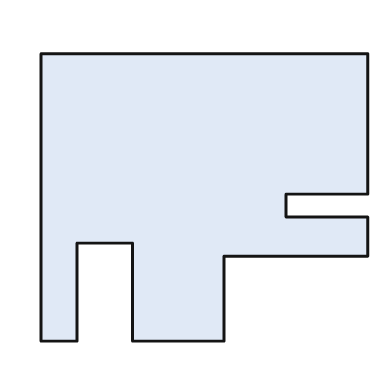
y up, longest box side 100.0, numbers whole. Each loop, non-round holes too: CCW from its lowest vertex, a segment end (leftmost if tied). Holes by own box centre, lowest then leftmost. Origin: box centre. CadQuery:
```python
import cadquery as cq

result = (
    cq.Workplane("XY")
    .moveTo(-50.0, -44.0)
    .lineTo(-39.0, -44.0)
    .lineTo(-39.0, -14.0)
    .lineTo(-22.0, -14.0)
    .lineTo(-22.0, -44.0)
    .lineTo(6.0, -44.0)
    .lineTo(6.0, -18.0)
    .lineTo(50.0, -18.0)
    .lineTo(50.0, -6.0)
    .lineTo(25.0, -6.0)
    .lineTo(25.0, 1.0)
    .lineTo(50.0, 1.0)
    .lineTo(50.0, 44.0)
    .lineTo(-50.0, 44.0)
    .close()
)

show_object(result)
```